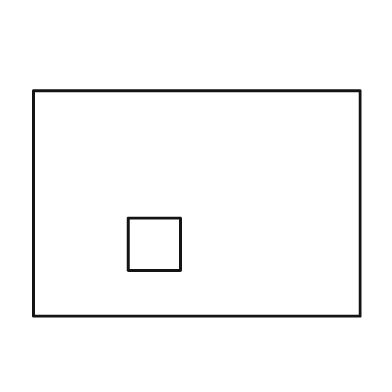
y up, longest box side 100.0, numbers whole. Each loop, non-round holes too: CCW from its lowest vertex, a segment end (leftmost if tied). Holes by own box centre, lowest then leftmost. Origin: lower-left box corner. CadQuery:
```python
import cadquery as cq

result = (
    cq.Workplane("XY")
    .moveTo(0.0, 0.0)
    .lineTo(100.0, 0.0)
    .lineTo(100.0, 69.0)
    .lineTo(0.0, 69.0)
    .close()
    .moveTo(29.0, 14.0)
    .lineTo(45.0, 14.0)
    .lineTo(45.0, 30.0)
    .lineTo(29.0, 30.0)
    .close()
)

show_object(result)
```